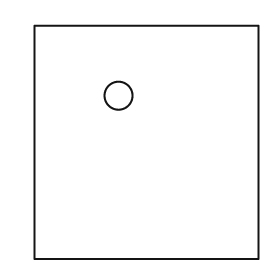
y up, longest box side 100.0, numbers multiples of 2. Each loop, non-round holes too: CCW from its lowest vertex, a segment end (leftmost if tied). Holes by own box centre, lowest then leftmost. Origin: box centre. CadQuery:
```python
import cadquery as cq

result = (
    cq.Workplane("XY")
    .moveTo(-48.0, -50.0)
    .lineTo(48.0, -50.0)
    .lineTo(48.0, 50.0)
    .lineTo(-48.0, 50.0)
    .close()
    .moveTo(-12.0, 20.0)
    .circle(6.0)
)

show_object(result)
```